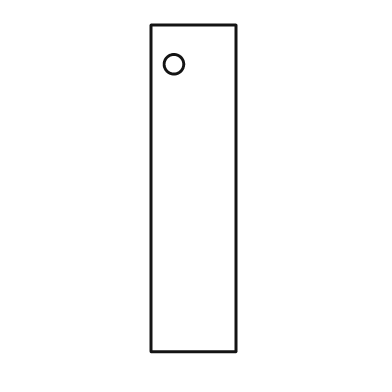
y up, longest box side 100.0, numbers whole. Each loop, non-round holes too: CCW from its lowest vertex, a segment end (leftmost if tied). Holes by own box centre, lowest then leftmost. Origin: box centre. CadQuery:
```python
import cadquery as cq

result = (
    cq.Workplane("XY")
    .moveTo(-13.0, -50.0)
    .lineTo(13.0, -50.0)
    .lineTo(13.0, 50.0)
    .lineTo(-13.0, 50.0)
    .close()
    .moveTo(-6.0, 38.0)
    .circle(3.0)
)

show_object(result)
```